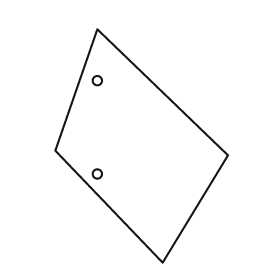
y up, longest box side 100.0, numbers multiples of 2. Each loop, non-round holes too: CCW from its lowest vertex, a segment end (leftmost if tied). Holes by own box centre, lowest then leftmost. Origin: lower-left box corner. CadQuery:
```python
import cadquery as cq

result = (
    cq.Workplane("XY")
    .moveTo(46.0, 0.0)
    .lineTo(74.0, 46.0)
    .lineTo(18.0, 100.0)
    .lineTo(0.0, 48.0)
    .close()
    .moveTo(18.0, 38.0)
    .circle(2.0)
    .moveTo(18.0, 78.0)
    .circle(2.0)
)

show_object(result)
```